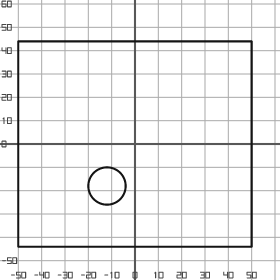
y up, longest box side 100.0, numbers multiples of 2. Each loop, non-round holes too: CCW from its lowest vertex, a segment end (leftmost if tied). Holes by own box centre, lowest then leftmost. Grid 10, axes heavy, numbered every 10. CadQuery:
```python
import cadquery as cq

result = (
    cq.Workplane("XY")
    .moveTo(-50.0, -44.0)
    .lineTo(50.0, -44.0)
    .lineTo(50.0, 44.0)
    .lineTo(-50.0, 44.0)
    .close()
    .moveTo(-12.0, -18.0)
    .circle(8.0)
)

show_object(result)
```